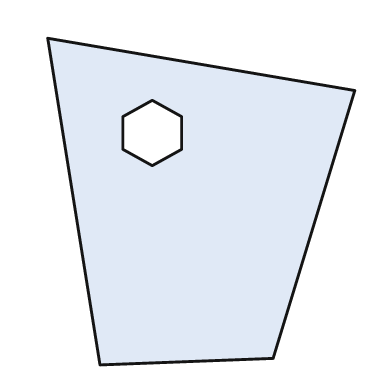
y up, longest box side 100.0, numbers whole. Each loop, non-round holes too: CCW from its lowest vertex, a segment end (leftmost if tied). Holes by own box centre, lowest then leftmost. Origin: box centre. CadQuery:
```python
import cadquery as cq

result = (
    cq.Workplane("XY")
    .moveTo(-31.0, -50.0)
    .lineTo(22.0, -48.0)
    .lineTo(47.0, 34.0)
    .lineTo(-47.0, 50.0)
    .close()
    .moveTo(-15.0, 11.0)
    .lineTo(-6.0, 16.0)
    .lineTo(-6.0, 26.0)
    .lineTo(-15.0, 31.0)
    .lineTo(-24.0, 26.0)
    .lineTo(-24.0, 16.0)
    .close()
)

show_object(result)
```